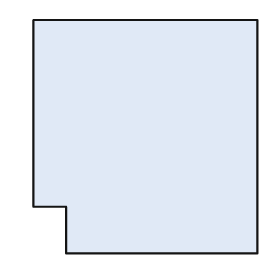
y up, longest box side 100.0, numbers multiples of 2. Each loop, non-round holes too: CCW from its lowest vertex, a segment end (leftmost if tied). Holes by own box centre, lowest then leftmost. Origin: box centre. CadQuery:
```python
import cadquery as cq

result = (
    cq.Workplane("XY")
    .moveTo(-34.0, -50.0)
    .lineTo(48.0, -50.0)
    .lineTo(48.0, 50.0)
    .lineTo(-48.0, 50.0)
    .lineTo(-48.0, -30.0)
    .lineTo(-34.0, -30.0)
    .close()
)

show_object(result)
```